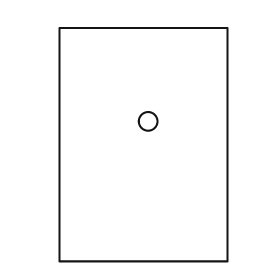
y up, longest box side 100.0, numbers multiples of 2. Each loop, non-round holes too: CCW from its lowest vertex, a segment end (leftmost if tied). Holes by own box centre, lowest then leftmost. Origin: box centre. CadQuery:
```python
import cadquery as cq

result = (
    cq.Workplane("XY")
    .moveTo(-36.0, -50.0)
    .lineTo(36.0, -50.0)
    .lineTo(36.0, 50.0)
    .lineTo(-36.0, 50.0)
    .close()
    .moveTo(2.0, 10.0)
    .circle(4.0)
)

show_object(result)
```